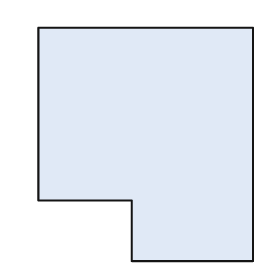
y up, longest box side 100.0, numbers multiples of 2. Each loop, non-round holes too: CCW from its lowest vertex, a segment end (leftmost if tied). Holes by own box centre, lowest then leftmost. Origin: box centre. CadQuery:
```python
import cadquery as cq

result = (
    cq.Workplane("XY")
    .moveTo(-6.0, -50.0)
    .lineTo(46.0, -50.0)
    .lineTo(46.0, 50.0)
    .lineTo(-46.0, 50.0)
    .lineTo(-46.0, -24.0)
    .lineTo(-6.0, -24.0)
    .close()
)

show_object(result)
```